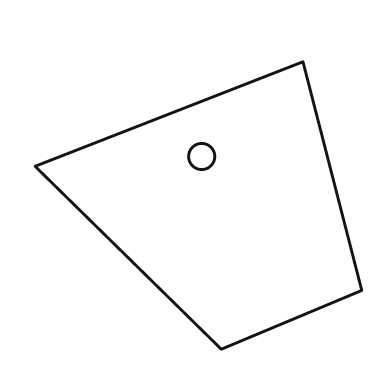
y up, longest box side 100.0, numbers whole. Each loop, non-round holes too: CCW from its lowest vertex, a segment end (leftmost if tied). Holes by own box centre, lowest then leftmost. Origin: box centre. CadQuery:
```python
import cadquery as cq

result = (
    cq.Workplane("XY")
    .moveTo(7.0, -44.0)
    .lineTo(50.0, -26.0)
    .lineTo(32.0, 44.0)
    .lineTo(-50.0, 12.0)
    .close()
    .moveTo(1.0, 15.0)
    .circle(4.0)
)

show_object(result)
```